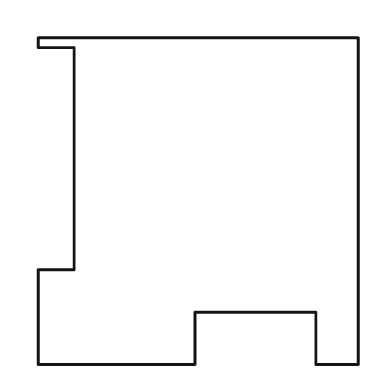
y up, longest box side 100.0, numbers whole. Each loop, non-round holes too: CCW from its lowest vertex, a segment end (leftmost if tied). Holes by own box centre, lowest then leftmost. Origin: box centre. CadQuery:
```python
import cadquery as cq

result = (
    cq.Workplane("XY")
    .moveTo(-49.0, -50.0)
    .lineTo(-1.0, -50.0)
    .lineTo(-1.0, -34.0)
    .lineTo(36.0, -34.0)
    .lineTo(36.0, -50.0)
    .lineTo(49.0, -50.0)
    .lineTo(49.0, 50.0)
    .lineTo(-49.0, 50.0)
    .lineTo(-49.0, 47.0)
    .lineTo(-38.0, 47.0)
    .lineTo(-38.0, -21.0)
    .lineTo(-49.0, -21.0)
    .close()
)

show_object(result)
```